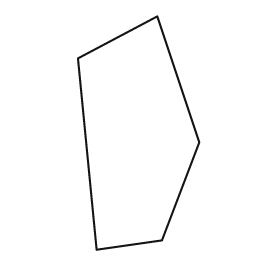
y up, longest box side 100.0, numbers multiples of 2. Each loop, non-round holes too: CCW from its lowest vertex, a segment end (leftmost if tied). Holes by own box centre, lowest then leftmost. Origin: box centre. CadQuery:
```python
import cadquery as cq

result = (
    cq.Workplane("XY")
    .moveTo(-18.0, -50.0)
    .lineTo(10.0, -46.0)
    .lineTo(26.0, -4.0)
    .lineTo(8.0, 50.0)
    .lineTo(-26.0, 32.0)
    .close()
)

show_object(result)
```